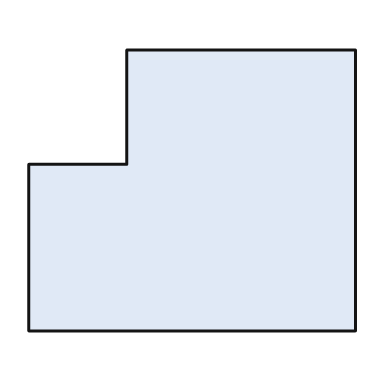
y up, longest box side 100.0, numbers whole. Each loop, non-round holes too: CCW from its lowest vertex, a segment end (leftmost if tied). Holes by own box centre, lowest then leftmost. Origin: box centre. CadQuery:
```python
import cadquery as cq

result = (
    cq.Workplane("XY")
    .moveTo(-50.0, -43.0)
    .lineTo(50.0, -43.0)
    .lineTo(50.0, 43.0)
    .lineTo(-20.0, 43.0)
    .lineTo(-20.0, 8.0)
    .lineTo(-50.0, 8.0)
    .close()
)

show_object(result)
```